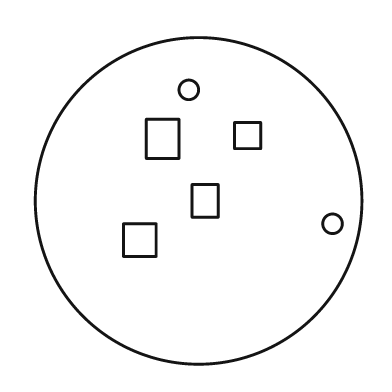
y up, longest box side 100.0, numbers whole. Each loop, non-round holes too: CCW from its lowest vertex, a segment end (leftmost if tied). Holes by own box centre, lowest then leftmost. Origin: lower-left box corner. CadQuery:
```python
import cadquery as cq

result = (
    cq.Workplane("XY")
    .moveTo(50.0, 50.0)
    .circle(50.0)
    .moveTo(27.0, 33.0)
    .lineTo(37.0, 33.0)
    .lineTo(37.0, 43.0)
    .lineTo(27.0, 43.0)
    .close()
    .moveTo(91.0, 43.0)
    .circle(3.0)
    .moveTo(48.0, 45.0)
    .lineTo(56.0, 45.0)
    .lineTo(56.0, 55.0)
    .lineTo(48.0, 55.0)
    .close()
    .moveTo(34.0, 63.0)
    .lineTo(44.0, 63.0)
    .lineTo(44.0, 75.0)
    .lineTo(34.0, 75.0)
    .close()
    .moveTo(61.0, 66.0)
    .lineTo(69.0, 66.0)
    .lineTo(69.0, 74.0)
    .lineTo(61.0, 74.0)
    .close()
    .moveTo(47.0, 84.0)
    .circle(3.0)
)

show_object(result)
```